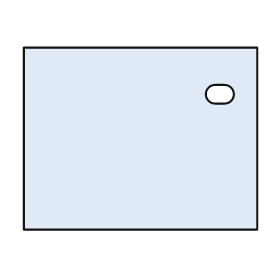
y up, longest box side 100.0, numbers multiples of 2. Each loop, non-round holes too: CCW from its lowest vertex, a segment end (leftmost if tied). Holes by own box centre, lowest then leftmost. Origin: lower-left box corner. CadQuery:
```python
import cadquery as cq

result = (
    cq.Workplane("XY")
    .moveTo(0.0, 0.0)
    .lineTo(100.0, 0.0)
    .lineTo(100.0, 78.0)
    .lineTo(0.0, 78.0)
    .close()
    .moveTo(82.0, 54.0)
    .lineTo(86.0, 54.0)
    .threePointArc((90.0, 58.0), (86.0, 62.0))
    .lineTo(82.0, 62.0)
    .threePointArc((78.0, 58.0), (82.0, 54.0))
    .close()
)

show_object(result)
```